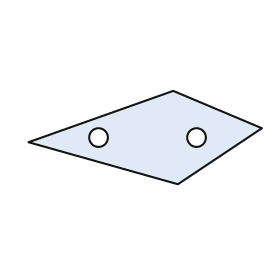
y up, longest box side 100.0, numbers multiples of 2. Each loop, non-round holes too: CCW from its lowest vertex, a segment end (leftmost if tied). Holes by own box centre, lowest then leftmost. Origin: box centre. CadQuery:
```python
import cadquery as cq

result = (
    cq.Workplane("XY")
    .moveTo(14.0, -20.0)
    .lineTo(50.0, 4.0)
    .lineTo(12.0, 20.0)
    .lineTo(-50.0, -2.0)
    .close()
    .moveTo(-20.0, 0.0)
    .circle(4.0)
    .moveTo(22.0, 0.0)
    .circle(4.0)
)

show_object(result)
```